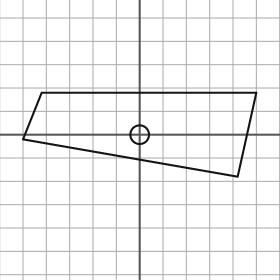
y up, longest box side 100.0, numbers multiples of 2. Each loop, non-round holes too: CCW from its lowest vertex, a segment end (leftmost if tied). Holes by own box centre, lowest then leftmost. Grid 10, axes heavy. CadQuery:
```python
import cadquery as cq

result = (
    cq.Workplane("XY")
    .moveTo(42.0, -18.0)
    .lineTo(50.0, 18.0)
    .lineTo(-42.0, 18.0)
    .lineTo(-50.0, -2.0)
    .close()
    .moveTo(0.0, 0.0)
    .circle(4.0)
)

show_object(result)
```